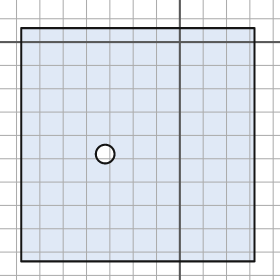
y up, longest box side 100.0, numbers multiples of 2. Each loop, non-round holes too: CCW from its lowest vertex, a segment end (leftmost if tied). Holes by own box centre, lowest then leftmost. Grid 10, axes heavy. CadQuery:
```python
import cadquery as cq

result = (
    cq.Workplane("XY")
    .moveTo(-68.0, -94.0)
    .lineTo(32.0, -94.0)
    .lineTo(32.0, 6.0)
    .lineTo(-68.0, 6.0)
    .close()
    .moveTo(-32.0, -48.0)
    .circle(4.0)
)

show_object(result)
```